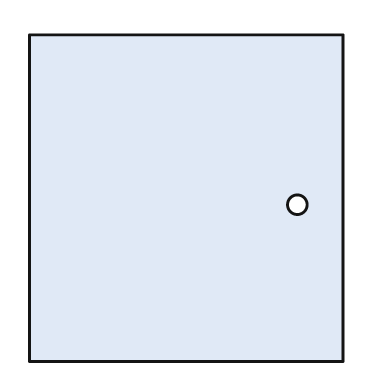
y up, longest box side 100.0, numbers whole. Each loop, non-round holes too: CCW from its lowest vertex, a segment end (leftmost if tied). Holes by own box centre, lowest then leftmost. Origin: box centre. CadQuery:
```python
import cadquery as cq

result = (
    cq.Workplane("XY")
    .moveTo(-48.0, -50.0)
    .lineTo(48.0, -50.0)
    .lineTo(48.0, 50.0)
    .lineTo(-48.0, 50.0)
    .close()
    .moveTo(34.0, -2.0)
    .circle(3.0)
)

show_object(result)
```